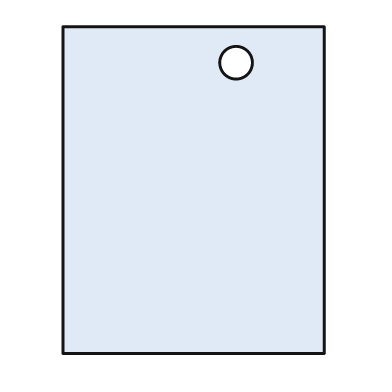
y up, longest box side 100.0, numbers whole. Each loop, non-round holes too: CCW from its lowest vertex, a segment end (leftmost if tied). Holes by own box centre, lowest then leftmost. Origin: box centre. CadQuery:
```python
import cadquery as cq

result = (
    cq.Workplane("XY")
    .moveTo(-40.0, -50.0)
    .lineTo(40.0, -50.0)
    .lineTo(40.0, 50.0)
    .lineTo(-40.0, 50.0)
    .close()
    .moveTo(13.0, 39.0)
    .circle(5.0)
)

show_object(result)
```